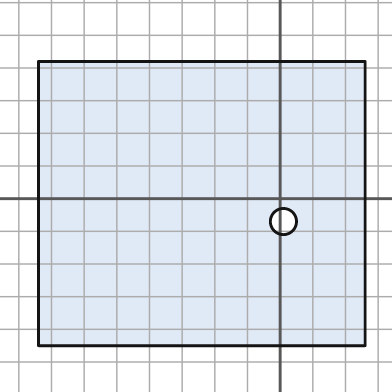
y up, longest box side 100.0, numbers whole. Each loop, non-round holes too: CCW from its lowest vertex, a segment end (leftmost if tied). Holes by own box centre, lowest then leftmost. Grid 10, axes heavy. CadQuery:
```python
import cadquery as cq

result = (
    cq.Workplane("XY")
    .moveTo(-74.0, -45.0)
    .lineTo(26.0, -45.0)
    .lineTo(26.0, 42.0)
    .lineTo(-74.0, 42.0)
    .close()
    .moveTo(1.0, -7.0)
    .circle(4.0)
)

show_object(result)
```